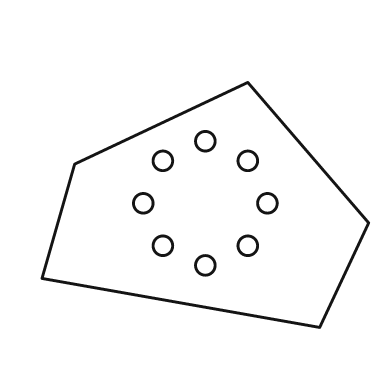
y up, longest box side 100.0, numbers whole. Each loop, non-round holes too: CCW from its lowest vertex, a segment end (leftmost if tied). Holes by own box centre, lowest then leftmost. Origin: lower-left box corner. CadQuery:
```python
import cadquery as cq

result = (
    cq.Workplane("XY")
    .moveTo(85.0, 0.0)
    .lineTo(100.0, 32.0)
    .lineTo(63.0, 75.0)
    .lineTo(10.0, 50.0)
    .lineTo(0.0, 15.0)
    .close()
    .moveTo(50.0, 19.0)
    .circle(3.0)
    .moveTo(37.0, 25.0)
    .circle(3.0)
    .moveTo(63.0, 25.0)
    .circle(3.0)
    .moveTo(31.0, 38.0)
    .circle(3.0)
    .moveTo(69.0, 38.0)
    .circle(3.0)
    .moveTo(37.0, 51.0)
    .circle(3.0)
    .moveTo(63.0, 51.0)
    .circle(3.0)
    .moveTo(50.0, 57.0)
    .circle(3.0)
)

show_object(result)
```